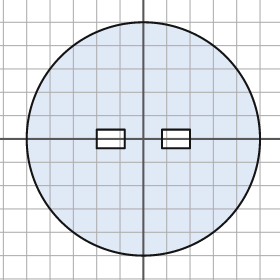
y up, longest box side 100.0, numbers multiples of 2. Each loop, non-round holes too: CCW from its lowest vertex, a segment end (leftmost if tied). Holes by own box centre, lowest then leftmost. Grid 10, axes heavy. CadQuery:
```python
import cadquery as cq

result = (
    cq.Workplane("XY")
    .moveTo(0.0, 0.0)
    .circle(50.0)
    .moveTo(-20.0, -4.0)
    .lineTo(-8.0, -4.0)
    .lineTo(-8.0, 4.0)
    .lineTo(-20.0, 4.0)
    .close()
    .moveTo(8.0, -4.0)
    .lineTo(20.0, -4.0)
    .lineTo(20.0, 4.0)
    .lineTo(8.0, 4.0)
    .close()
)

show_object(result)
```